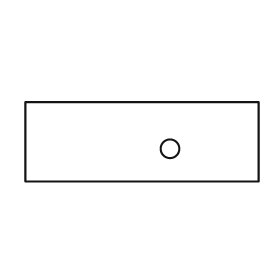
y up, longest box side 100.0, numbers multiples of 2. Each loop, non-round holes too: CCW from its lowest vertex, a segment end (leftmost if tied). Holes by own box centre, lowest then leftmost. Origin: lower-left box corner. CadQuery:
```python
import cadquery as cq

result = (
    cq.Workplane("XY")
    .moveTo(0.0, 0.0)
    .lineTo(100.0, 0.0)
    .lineTo(100.0, 34.0)
    .lineTo(0.0, 34.0)
    .close()
    .moveTo(62.0, 14.0)
    .circle(4.0)
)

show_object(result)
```